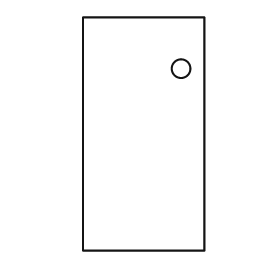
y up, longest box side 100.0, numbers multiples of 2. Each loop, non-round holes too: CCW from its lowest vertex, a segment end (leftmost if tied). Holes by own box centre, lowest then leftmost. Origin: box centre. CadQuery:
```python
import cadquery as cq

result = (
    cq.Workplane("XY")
    .moveTo(-26.0, -50.0)
    .lineTo(26.0, -50.0)
    .lineTo(26.0, 50.0)
    .lineTo(-26.0, 50.0)
    .close()
    .moveTo(16.0, 28.0)
    .circle(4.0)
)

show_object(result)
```